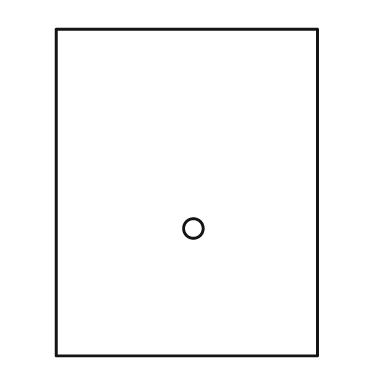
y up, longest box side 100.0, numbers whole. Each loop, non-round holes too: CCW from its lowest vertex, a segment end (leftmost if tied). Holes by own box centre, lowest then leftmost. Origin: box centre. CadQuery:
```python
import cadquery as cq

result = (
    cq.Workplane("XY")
    .moveTo(-40.0, -50.0)
    .lineTo(40.0, -50.0)
    .lineTo(40.0, 50.0)
    .lineTo(-40.0, 50.0)
    .close()
    .moveTo(2.0, -11.0)
    .circle(3.0)
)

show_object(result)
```